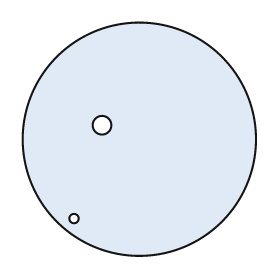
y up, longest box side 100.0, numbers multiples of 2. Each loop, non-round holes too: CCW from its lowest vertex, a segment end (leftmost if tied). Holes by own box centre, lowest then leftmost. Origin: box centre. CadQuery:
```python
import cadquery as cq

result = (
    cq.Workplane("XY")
    .moveTo(0.0, 0.0)
    .circle(50.0)
    .moveTo(-28.0, -34.0)
    .circle(2.0)
    .moveTo(-16.0, 6.0)
    .circle(4.0)
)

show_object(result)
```